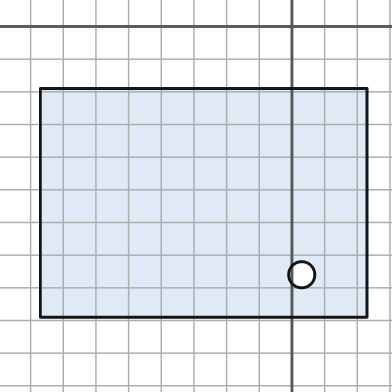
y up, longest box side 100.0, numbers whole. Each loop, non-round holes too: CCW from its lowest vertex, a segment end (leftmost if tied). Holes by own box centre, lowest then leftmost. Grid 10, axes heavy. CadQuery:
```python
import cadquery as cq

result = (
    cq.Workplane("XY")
    .moveTo(-77.0, -89.0)
    .lineTo(23.0, -89.0)
    .lineTo(23.0, -19.0)
    .lineTo(-77.0, -19.0)
    .close()
    .moveTo(3.0, -76.0)
    .circle(4.0)
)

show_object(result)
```